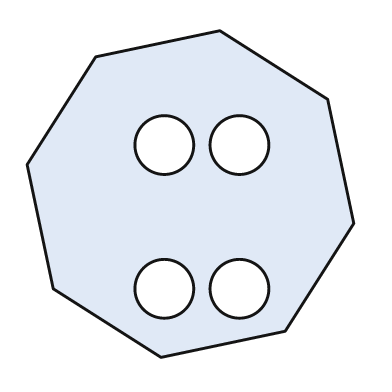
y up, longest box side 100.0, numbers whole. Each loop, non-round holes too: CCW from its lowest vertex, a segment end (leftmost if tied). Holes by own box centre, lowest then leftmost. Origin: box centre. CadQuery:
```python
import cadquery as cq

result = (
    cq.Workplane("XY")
    .moveTo(-9.0, -50.0)
    .lineTo(29.0, -42.0)
    .lineTo(50.0, -9.0)
    .lineTo(42.0, 29.0)
    .lineTo(9.0, 50.0)
    .lineTo(-29.0, 42.0)
    .lineTo(-50.0, 9.0)
    .lineTo(-42.0, -29.0)
    .close()
    .moveTo(-8.0, -29.0)
    .circle(9.0)
    .moveTo(15.0, -29.0)
    .circle(9.0)
    .moveTo(-8.0, 15.0)
    .circle(9.0)
    .moveTo(15.0, 15.0)
    .circle(9.0)
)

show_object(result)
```